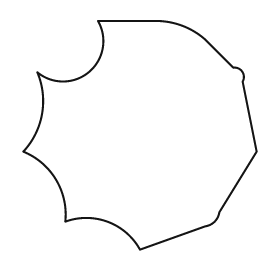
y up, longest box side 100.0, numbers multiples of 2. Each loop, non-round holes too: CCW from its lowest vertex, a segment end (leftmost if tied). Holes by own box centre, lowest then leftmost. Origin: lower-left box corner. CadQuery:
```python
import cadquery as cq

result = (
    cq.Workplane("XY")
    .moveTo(50.0, 0.0)
    .lineTo(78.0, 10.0)
    .threePointArc((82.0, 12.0), (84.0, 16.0))
    .lineTo(100.0, 42.0)
    .lineTo(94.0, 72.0)
    .threePointArc((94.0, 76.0), (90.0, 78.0))
    .lineTo(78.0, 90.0)
    .threePointArc((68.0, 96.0), (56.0, 98.0))
    .lineTo(32.0, 98.0)
    .threePointArc((28.0, 76.0), (6.0, 76.0))
    .threePointArc((8.0, 58.0), (0.0, 42.0))
    .threePointArc((14.0, 30.0), (18.0, 12.0))
    .threePointArc((36.0, 12.0), (50.0, 0.0))
    .close()
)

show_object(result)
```